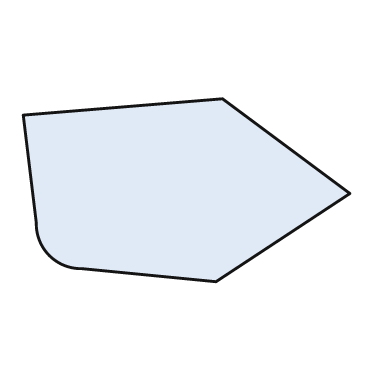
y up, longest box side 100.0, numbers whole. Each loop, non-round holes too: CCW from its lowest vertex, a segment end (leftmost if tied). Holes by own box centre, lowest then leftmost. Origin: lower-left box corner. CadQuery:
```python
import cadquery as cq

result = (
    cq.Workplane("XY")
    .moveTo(59.0, 0.0)
    .lineTo(100.0, 27.0)
    .lineTo(61.0, 56.0)
    .lineTo(0.0, 51.0)
    .lineTo(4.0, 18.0)
    .threePointArc((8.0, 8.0), (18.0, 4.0))
    .close()
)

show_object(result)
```